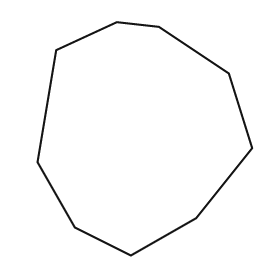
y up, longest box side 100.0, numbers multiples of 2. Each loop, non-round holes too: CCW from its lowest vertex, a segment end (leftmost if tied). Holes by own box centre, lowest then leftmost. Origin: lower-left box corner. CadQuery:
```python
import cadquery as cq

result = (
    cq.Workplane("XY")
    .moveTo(40.0, 0.0)
    .lineTo(68.0, 16.0)
    .lineTo(92.0, 46.0)
    .lineTo(82.0, 78.0)
    .lineTo(52.0, 98.0)
    .lineTo(34.0, 100.0)
    .lineTo(8.0, 88.0)
    .lineTo(0.0, 40.0)
    .lineTo(16.0, 12.0)
    .close()
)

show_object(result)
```